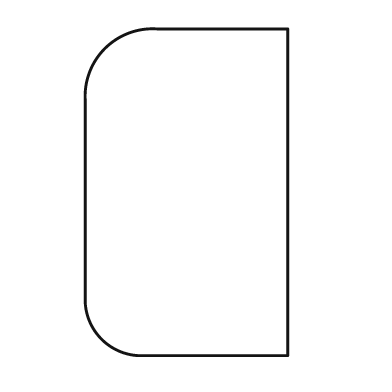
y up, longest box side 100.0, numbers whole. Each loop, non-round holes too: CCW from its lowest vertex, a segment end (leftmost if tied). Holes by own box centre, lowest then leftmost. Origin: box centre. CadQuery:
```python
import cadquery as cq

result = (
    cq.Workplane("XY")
    .moveTo(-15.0, -50.0)
    .lineTo(31.0, -50.0)
    .lineTo(31.0, 50.0)
    .lineTo(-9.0, 50.0)
    .threePointArc((-25.0, 44.0), (-31.0, 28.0))
    .lineTo(-31.0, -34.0)
    .threePointArc((-26.0, -45.0), (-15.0, -50.0))
    .close()
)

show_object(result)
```